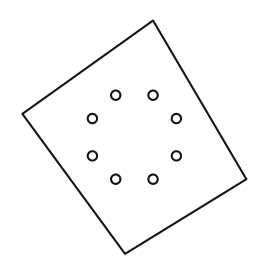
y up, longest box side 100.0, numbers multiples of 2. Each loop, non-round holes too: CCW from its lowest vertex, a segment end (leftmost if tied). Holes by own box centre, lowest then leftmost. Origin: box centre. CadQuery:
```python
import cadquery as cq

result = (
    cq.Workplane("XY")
    .moveTo(-4.0, -50.0)
    .lineTo(48.0, -18.0)
    .lineTo(8.0, 50.0)
    .lineTo(-48.0, 10.0)
    .close()
    .moveTo(-8.0, -18.0)
    .circle(2.0)
    .moveTo(8.0, -18.0)
    .circle(2.0)
    .moveTo(-18.0, -8.0)
    .circle(2.0)
    .moveTo(18.0, -8.0)
    .circle(2.0)
    .moveTo(-18.0, 8.0)
    .circle(2.0)
    .moveTo(18.0, 8.0)
    .circle(2.0)
    .moveTo(-8.0, 18.0)
    .circle(2.0)
    .moveTo(8.0, 18.0)
    .circle(2.0)
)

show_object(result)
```